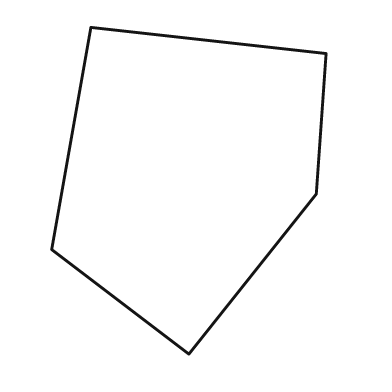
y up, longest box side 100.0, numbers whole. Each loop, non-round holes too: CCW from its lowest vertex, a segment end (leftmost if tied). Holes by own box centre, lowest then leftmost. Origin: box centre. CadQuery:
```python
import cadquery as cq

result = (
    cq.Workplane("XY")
    .moveTo(0.0, -50.0)
    .lineTo(39.0, -1.0)
    .lineTo(42.0, 42.0)
    .lineTo(-30.0, 50.0)
    .lineTo(-42.0, -18.0)
    .close()
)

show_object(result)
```